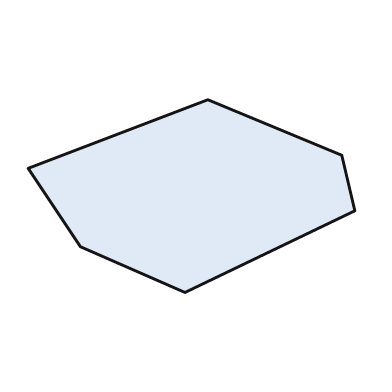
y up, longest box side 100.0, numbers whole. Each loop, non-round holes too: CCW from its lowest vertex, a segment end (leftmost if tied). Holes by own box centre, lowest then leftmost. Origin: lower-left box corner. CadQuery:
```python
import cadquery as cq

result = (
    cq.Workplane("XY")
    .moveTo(48.0, 0.0)
    .lineTo(100.0, 25.0)
    .lineTo(96.0, 42.0)
    .lineTo(55.0, 59.0)
    .lineTo(0.0, 38.0)
    .lineTo(16.0, 14.0)
    .close()
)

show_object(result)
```